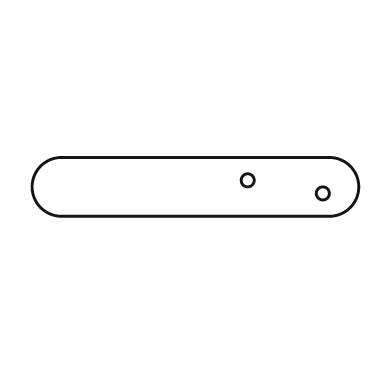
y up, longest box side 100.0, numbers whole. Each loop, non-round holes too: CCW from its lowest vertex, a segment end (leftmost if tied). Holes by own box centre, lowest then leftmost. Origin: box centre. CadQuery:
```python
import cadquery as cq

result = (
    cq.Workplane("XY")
    .moveTo(-41.0, -9.0)
    .lineTo(41.0, -9.0)
    .threePointArc((50.0, 0.0), (41.0, 9.0))
    .lineTo(-41.0, 9.0)
    .threePointArc((-50.0, 0.0), (-41.0, -9.0))
    .close()
    .moveTo(39.0, -2.0)
    .circle(2.0)
    .moveTo(16.0, 2.0)
    .circle(2.0)
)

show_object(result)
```